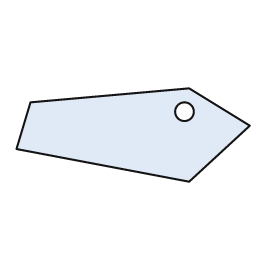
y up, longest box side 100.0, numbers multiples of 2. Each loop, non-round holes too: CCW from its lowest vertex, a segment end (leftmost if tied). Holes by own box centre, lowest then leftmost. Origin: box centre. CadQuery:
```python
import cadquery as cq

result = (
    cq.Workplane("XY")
    .moveTo(24.0, -20.0)
    .lineTo(50.0, 4.0)
    .lineTo(24.0, 20.0)
    .lineTo(-44.0, 14.0)
    .lineTo(-50.0, -6.0)
    .close()
    .moveTo(22.0, 10.0)
    .circle(4.0)
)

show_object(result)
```